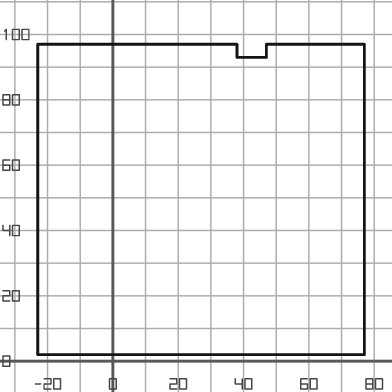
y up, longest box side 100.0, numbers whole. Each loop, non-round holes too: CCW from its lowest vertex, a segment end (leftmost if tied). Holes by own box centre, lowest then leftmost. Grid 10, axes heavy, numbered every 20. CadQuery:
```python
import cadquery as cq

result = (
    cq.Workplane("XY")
    .moveTo(-23.0, 2.0)
    .lineTo(77.0, 2.0)
    .lineTo(77.0, 97.0)
    .lineTo(47.0, 97.0)
    .lineTo(47.0, 93.0)
    .lineTo(38.0, 93.0)
    .lineTo(38.0, 97.0)
    .lineTo(-23.0, 97.0)
    .close()
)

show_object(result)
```